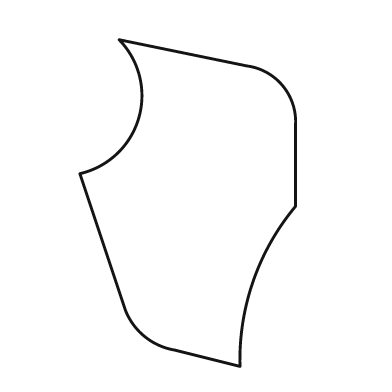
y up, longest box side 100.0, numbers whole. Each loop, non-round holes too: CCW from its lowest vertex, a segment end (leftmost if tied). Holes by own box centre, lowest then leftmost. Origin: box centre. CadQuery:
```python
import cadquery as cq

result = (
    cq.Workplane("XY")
    .moveTo(16.0, -50.0)
    .threePointArc((20.0, -24.0), (33.0, -1.0))
    .lineTo(33.0, 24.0)
    .threePointArc((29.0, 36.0), (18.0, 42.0))
    .lineTo(-21.0, 50.0)
    .threePointArc((-15.0, 26.0), (-33.0, 9.0))
    .lineTo(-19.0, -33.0)
    .threePointArc((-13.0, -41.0), (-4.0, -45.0))
    .close()
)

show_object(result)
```